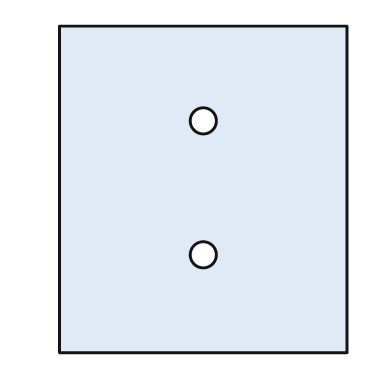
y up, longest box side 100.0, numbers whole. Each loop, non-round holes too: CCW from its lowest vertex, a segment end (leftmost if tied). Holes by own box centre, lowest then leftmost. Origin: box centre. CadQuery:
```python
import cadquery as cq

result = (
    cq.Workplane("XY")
    .moveTo(-44.0, -50.0)
    .lineTo(44.0, -50.0)
    .lineTo(44.0, 50.0)
    .lineTo(-44.0, 50.0)
    .close()
    .moveTo(0.0, -20.0)
    .circle(4.0)
    .moveTo(0.0, 21.0)
    .circle(4.0)
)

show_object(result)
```